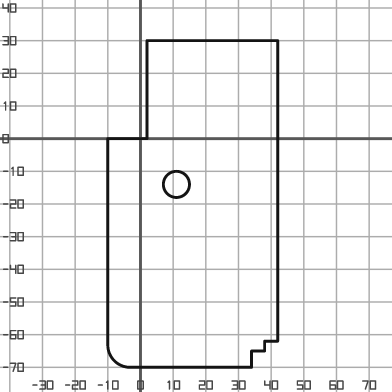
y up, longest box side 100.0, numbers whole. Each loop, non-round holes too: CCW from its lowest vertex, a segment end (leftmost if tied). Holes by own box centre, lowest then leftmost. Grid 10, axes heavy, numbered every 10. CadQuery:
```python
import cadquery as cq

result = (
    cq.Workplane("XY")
    .moveTo(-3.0, -70.0)
    .lineTo(34.0, -70.0)
    .lineTo(34.0, -65.0)
    .lineTo(38.0, -65.0)
    .lineTo(38.0, -62.0)
    .lineTo(42.0, -62.0)
    .lineTo(42.0, 30.0)
    .lineTo(2.0, 30.0)
    .lineTo(2.0, 0.0)
    .lineTo(-10.0, 0.0)
    .lineTo(-10.0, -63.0)
    .threePointArc((-8.0, -68.0), (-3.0, -70.0))
    .close()
    .moveTo(11.0, -14.0)
    .circle(4.0)
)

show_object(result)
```